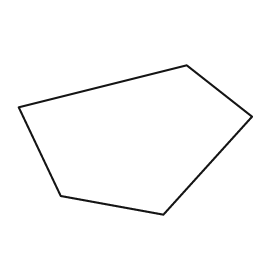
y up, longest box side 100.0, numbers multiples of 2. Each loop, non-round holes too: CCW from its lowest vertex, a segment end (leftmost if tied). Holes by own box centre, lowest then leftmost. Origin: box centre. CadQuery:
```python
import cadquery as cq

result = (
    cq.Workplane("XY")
    .moveTo(12.0, -32.0)
    .lineTo(50.0, 10.0)
    .lineTo(22.0, 32.0)
    .lineTo(-50.0, 14.0)
    .lineTo(-32.0, -24.0)
    .close()
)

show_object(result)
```